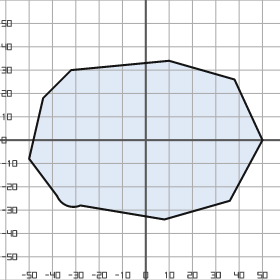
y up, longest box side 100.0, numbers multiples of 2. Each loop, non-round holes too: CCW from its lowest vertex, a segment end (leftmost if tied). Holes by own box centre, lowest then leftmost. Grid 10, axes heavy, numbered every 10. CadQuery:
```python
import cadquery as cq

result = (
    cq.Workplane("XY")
    .moveTo(8.0, -34.0)
    .lineTo(36.0, -26.0)
    .lineTo(50.0, 0.0)
    .lineTo(38.0, 26.0)
    .lineTo(10.0, 34.0)
    .lineTo(-32.0, 30.0)
    .lineTo(-44.0, 18.0)
    .lineTo(-50.0, -8.0)
    .lineTo(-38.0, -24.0)
    .threePointArc((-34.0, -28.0), (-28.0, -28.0))
    .close()
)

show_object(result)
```